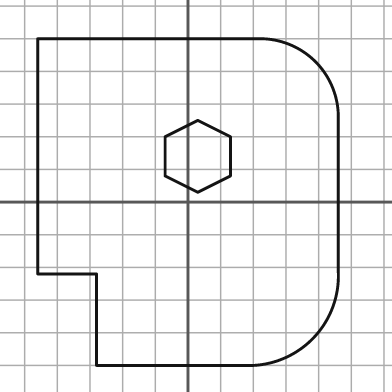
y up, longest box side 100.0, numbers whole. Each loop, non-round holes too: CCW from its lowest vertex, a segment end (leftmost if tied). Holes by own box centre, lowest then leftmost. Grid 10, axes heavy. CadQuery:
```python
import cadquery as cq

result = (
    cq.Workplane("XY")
    .moveTo(-28.0, -50.0)
    .lineTo(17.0, -50.0)
    .threePointArc((38.0, -42.0), (46.0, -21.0))
    .lineTo(46.0, 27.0)
    .threePointArc((39.0, 43.0), (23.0, 50.0))
    .lineTo(-46.0, 50.0)
    .lineTo(-46.0, -22.0)
    .lineTo(-28.0, -22.0)
    .close()
    .moveTo(3.0, 3.0)
    .lineTo(13.0, 8.0)
    .lineTo(13.0, 20.0)
    .lineTo(3.0, 25.0)
    .lineTo(-7.0, 20.0)
    .lineTo(-7.0, 8.0)
    .close()
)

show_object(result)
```